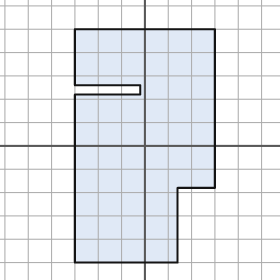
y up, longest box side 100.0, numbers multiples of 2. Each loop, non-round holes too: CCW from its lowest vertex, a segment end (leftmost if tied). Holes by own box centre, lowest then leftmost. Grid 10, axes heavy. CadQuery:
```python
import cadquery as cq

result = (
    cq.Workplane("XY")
    .moveTo(-30.0, -50.0)
    .lineTo(14.0, -50.0)
    .lineTo(14.0, -18.0)
    .lineTo(30.0, -18.0)
    .lineTo(30.0, 50.0)
    .lineTo(-30.0, 50.0)
    .lineTo(-30.0, 26.0)
    .lineTo(-2.0, 26.0)
    .lineTo(-2.0, 22.0)
    .lineTo(-30.0, 22.0)
    .close()
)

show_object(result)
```